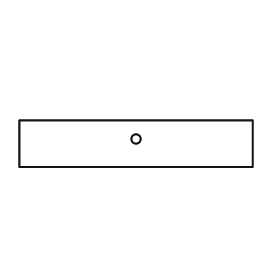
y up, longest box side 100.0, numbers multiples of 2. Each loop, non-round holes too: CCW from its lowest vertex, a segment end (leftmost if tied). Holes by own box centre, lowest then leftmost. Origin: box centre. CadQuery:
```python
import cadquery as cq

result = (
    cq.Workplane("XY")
    .moveTo(-50.0, -10.0)
    .lineTo(50.0, -10.0)
    .lineTo(50.0, 10.0)
    .lineTo(-50.0, 10.0)
    .close()
    .moveTo(0.0, 2.0)
    .circle(2.0)
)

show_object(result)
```